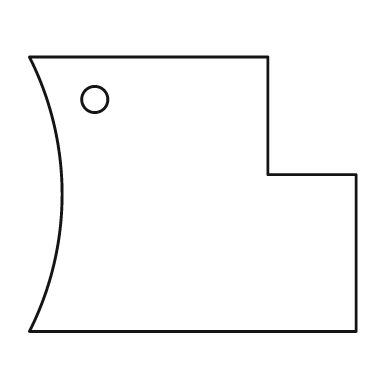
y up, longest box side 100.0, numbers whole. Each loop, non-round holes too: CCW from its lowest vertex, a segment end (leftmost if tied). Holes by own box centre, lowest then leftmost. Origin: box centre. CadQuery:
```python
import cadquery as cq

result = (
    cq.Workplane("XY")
    .moveTo(-50.0, -42.0)
    .lineTo(50.0, -42.0)
    .lineTo(50.0, 6.0)
    .lineTo(23.0, 6.0)
    .lineTo(23.0, 42.0)
    .lineTo(-50.0, 42.0)
    .threePointArc((-40.0, 0.0), (-50.0, -42.0))
    .close()
    .moveTo(-30.0, 29.0)
    .circle(4.0)
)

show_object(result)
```